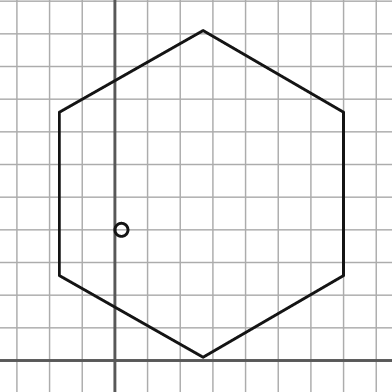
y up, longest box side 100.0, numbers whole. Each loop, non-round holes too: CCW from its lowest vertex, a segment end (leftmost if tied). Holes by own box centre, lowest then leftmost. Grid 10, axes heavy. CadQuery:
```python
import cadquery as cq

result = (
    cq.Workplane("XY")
    .moveTo(27.0, 1.0)
    .lineTo(70.0, 26.0)
    .lineTo(70.0, 76.0)
    .lineTo(27.0, 101.0)
    .lineTo(-17.0, 76.0)
    .lineTo(-17.0, 26.0)
    .close()
    .moveTo(2.0, 40.0)
    .circle(2.0)
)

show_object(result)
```